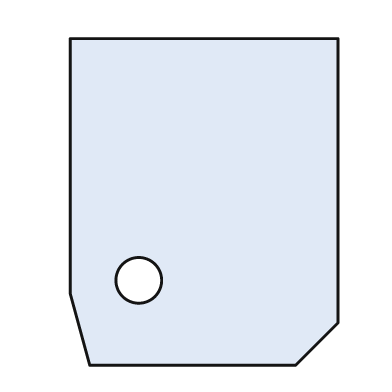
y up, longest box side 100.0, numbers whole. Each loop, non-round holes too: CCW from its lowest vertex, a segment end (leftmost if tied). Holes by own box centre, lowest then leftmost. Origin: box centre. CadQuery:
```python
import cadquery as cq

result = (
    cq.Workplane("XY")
    .moveTo(-35.0, -50.0)
    .lineTo(28.0, -50.0)
    .lineTo(41.0, -37.0)
    .lineTo(41.0, 50.0)
    .lineTo(-41.0, 50.0)
    .lineTo(-41.0, -28.0)
    .close()
    .moveTo(-20.0, -24.0)
    .circle(7.0)
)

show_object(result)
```